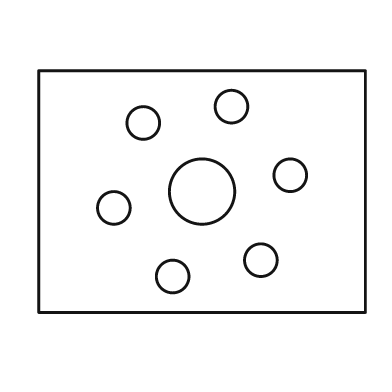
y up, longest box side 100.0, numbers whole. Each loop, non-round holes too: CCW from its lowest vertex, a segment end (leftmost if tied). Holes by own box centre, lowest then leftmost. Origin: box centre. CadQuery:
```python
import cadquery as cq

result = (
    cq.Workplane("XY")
    .moveTo(-50.0, -37.0)
    .lineTo(50.0, -37.0)
    .lineTo(50.0, 37.0)
    .lineTo(-50.0, 37.0)
    .close()
    .moveTo(-9.0, -26.0)
    .circle(5.0)
    .moveTo(18.0, -21.0)
    .circle(5.0)
    .moveTo(-27.0, -5.0)
    .circle(5.0)
    .moveTo(0.0, 0.0)
    .circle(10.0)
    .moveTo(27.0, 5.0)
    .circle(5.0)
    .moveTo(-18.0, 21.0)
    .circle(5.0)
    .moveTo(9.0, 26.0)
    .circle(5.0)
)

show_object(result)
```